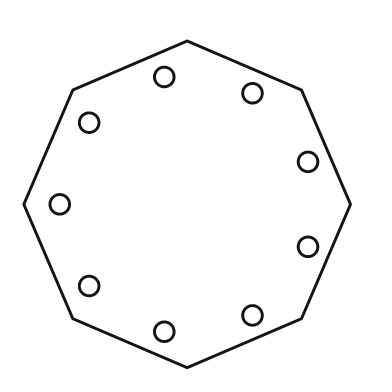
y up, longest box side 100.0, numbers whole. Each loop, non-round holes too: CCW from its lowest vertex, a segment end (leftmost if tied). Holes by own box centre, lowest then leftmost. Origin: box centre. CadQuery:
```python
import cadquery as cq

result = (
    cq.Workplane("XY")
    .moveTo(0.0, -50.0)
    .lineTo(35.0, -35.0)
    .lineTo(50.0, 0.0)
    .lineTo(35.0, 35.0)
    .lineTo(0.0, 50.0)
    .lineTo(-35.0, 35.0)
    .lineTo(-50.0, 0.0)
    .lineTo(-35.0, -35.0)
    .close()
    .moveTo(-7.0, -39.0)
    .circle(3.0)
    .moveTo(20.0, -34.0)
    .circle(3.0)
    .moveTo(-30.0, -25.0)
    .circle(3.0)
    .moveTo(37.0, -13.0)
    .circle(3.0)
    .moveTo(-39.0, 0.0)
    .circle(3.0)
    .moveTo(37.0, 13.0)
    .circle(3.0)
    .moveTo(-30.0, 25.0)
    .circle(3.0)
    .moveTo(20.0, 34.0)
    .circle(3.0)
    .moveTo(-7.0, 39.0)
    .circle(3.0)
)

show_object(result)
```